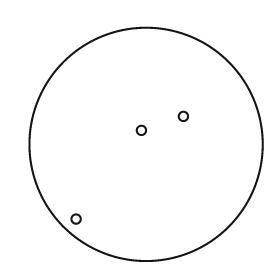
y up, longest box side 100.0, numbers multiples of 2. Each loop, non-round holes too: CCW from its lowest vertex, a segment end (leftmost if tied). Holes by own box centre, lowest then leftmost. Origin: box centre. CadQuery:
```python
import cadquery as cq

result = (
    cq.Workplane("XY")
    .moveTo(0.0, 0.0)
    .circle(50.0)
    .moveTo(-30.0, -32.0)
    .circle(2.0)
    .moveTo(-2.0, 6.0)
    .circle(2.0)
    .moveTo(16.0, 12.0)
    .circle(2.0)
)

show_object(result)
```